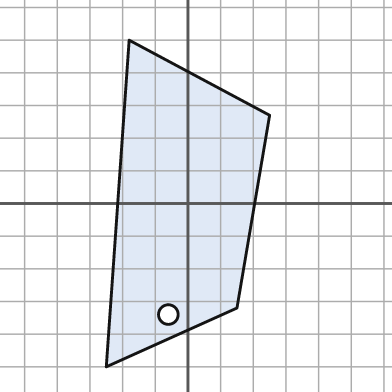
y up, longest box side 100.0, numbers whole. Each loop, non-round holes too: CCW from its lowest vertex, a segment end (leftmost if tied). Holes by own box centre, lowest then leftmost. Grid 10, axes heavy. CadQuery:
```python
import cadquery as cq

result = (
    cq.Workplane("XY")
    .moveTo(-25.0, -50.0)
    .lineTo(15.0, -32.0)
    .lineTo(25.0, 27.0)
    .lineTo(-18.0, 50.0)
    .close()
    .moveTo(-6.0, -34.0)
    .circle(3.0)
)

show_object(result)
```